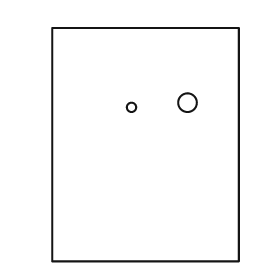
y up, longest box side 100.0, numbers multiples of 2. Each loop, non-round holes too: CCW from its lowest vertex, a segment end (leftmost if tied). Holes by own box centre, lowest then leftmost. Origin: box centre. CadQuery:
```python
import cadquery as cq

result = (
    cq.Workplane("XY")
    .moveTo(-40.0, -50.0)
    .lineTo(40.0, -50.0)
    .lineTo(40.0, 50.0)
    .lineTo(-40.0, 50.0)
    .close()
    .moveTo(-6.0, 16.0)
    .circle(2.0)
    .moveTo(18.0, 18.0)
    .circle(4.0)
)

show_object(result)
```